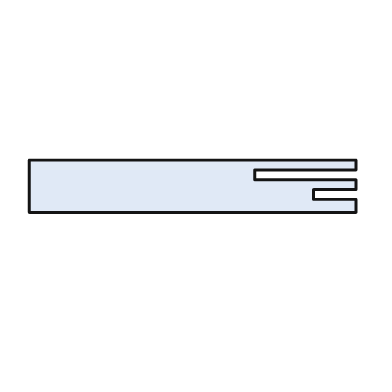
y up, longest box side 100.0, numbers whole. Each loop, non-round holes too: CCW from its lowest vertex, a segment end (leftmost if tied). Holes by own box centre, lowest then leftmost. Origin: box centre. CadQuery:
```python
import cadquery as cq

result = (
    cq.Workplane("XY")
    .moveTo(-50.0, -8.0)
    .lineTo(50.0, -8.0)
    .lineTo(50.0, -4.0)
    .lineTo(37.0, -4.0)
    .lineTo(37.0, -1.0)
    .lineTo(50.0, -1.0)
    .lineTo(50.0, 2.0)
    .lineTo(19.0, 2.0)
    .lineTo(19.0, 5.0)
    .lineTo(50.0, 5.0)
    .lineTo(50.0, 8.0)
    .lineTo(-50.0, 8.0)
    .close()
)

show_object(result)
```